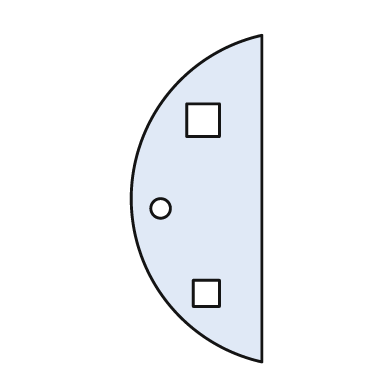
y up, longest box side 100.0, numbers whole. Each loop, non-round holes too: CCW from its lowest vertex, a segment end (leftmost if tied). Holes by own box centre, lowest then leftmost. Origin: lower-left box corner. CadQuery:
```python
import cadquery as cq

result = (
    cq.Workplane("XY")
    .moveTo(40.0, 0.0)
    .lineTo(40.0, 100.0)
    .threePointArc((0.0, 50.0), (40.0, 0.0))
    .close()
    .moveTo(19.0, 17.0)
    .lineTo(27.0, 17.0)
    .lineTo(27.0, 25.0)
    .lineTo(19.0, 25.0)
    .close()
    .moveTo(9.0, 47.0)
    .circle(3.0)
    .moveTo(17.0, 69.0)
    .lineTo(27.0, 69.0)
    .lineTo(27.0, 79.0)
    .lineTo(17.0, 79.0)
    .close()
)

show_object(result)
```